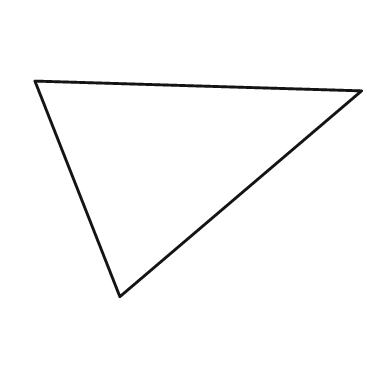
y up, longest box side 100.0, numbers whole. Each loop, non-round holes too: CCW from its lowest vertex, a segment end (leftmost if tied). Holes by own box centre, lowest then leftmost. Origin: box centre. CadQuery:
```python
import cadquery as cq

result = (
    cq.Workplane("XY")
    .moveTo(-24.0, -33.0)
    .lineTo(50.0, 30.0)
    .lineTo(-50.0, 33.0)
    .close()
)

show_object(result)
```